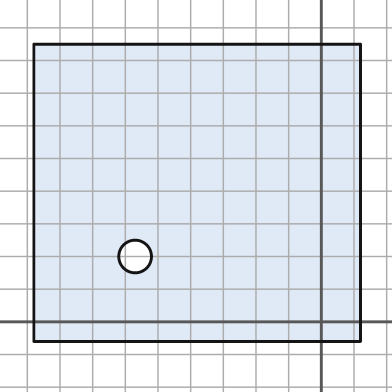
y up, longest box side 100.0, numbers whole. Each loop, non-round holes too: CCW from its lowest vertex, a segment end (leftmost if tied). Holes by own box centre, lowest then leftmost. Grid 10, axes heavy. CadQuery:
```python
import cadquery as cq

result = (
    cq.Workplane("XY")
    .moveTo(-88.0, -6.0)
    .lineTo(12.0, -6.0)
    .lineTo(12.0, 85.0)
    .lineTo(-88.0, 85.0)
    .close()
    .moveTo(-57.0, 20.0)
    .circle(5.0)
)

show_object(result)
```